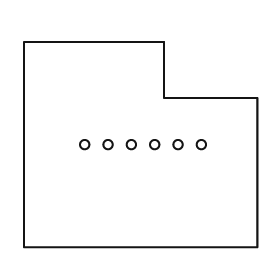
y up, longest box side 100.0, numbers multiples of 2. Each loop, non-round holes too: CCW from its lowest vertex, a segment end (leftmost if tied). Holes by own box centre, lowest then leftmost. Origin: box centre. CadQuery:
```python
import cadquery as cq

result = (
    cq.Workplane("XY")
    .moveTo(-50.0, -44.0)
    .lineTo(50.0, -44.0)
    .lineTo(50.0, 20.0)
    .lineTo(10.0, 20.0)
    .lineTo(10.0, 44.0)
    .lineTo(-50.0, 44.0)
    .close()
    .moveTo(-24.0, 0.0)
    .circle(2.0)
    .moveTo(-14.0, 0.0)
    .circle(2.0)
    .moveTo(-4.0, 0.0)
    .circle(2.0)
    .moveTo(6.0, 0.0)
    .circle(2.0)
    .moveTo(16.0, 0.0)
    .circle(2.0)
    .moveTo(26.0, 0.0)
    .circle(2.0)
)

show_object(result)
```